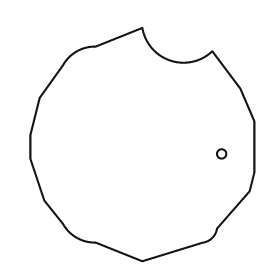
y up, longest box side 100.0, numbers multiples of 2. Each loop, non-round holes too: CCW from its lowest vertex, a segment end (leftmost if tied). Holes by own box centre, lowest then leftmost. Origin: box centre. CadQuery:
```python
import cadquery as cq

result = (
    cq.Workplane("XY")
    .moveTo(0.0, -50.0)
    .lineTo(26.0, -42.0)
    .threePointArc((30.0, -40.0), (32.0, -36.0))
    .lineTo(46.0, -20.0)
    .lineTo(48.0, -12.0)
    .lineTo(48.0, 10.0)
    .lineTo(42.0, 24.0)
    .lineTo(30.0, 40.0)
    .threePointArc((12.0, 36.0), (0.0, 50.0))
    .lineTo(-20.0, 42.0)
    .threePointArc((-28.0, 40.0), (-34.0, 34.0))
    .lineTo(-44.0, 20.0)
    .lineTo(-48.0, 4.0)
    .lineTo(-48.0, -6.0)
    .lineTo(-42.0, -24.0)
    .lineTo(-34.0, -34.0)
    .threePointArc((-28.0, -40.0), (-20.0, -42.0))
    .close()
    .moveTo(34.0, -4.0)
    .circle(2.0)
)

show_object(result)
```